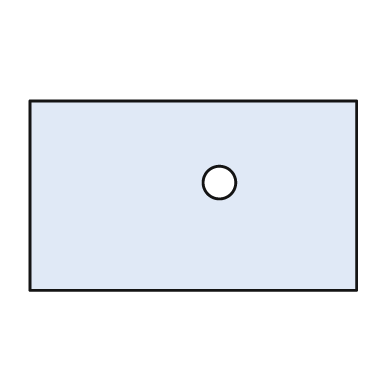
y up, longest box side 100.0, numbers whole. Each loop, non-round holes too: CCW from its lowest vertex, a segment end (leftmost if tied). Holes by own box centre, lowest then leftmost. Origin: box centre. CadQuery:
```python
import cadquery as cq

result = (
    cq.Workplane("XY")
    .moveTo(-50.0, -29.0)
    .lineTo(50.0, -29.0)
    .lineTo(50.0, 29.0)
    .lineTo(-50.0, 29.0)
    .close()
    .moveTo(8.0, 4.0)
    .circle(5.0)
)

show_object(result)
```